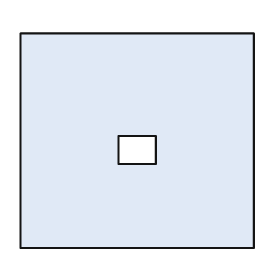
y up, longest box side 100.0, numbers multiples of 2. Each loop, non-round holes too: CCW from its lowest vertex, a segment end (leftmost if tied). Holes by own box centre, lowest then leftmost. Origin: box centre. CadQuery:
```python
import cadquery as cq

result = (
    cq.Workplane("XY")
    .moveTo(-50.0, -46.0)
    .lineTo(50.0, -46.0)
    .lineTo(50.0, 46.0)
    .lineTo(-50.0, 46.0)
    .close()
    .moveTo(-8.0, -10.0)
    .lineTo(8.0, -10.0)
    .lineTo(8.0, 2.0)
    .lineTo(-8.0, 2.0)
    .close()
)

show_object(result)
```